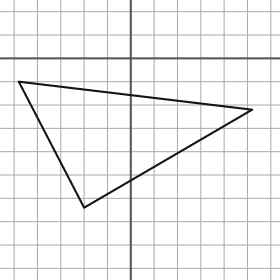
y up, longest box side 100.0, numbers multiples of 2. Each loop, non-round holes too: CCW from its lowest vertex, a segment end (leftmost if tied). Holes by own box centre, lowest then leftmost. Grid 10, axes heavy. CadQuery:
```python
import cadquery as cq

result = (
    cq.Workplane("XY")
    .moveTo(-20.0, -64.0)
    .lineTo(52.0, -22.0)
    .lineTo(-48.0, -10.0)
    .close()
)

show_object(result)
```